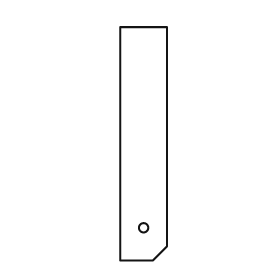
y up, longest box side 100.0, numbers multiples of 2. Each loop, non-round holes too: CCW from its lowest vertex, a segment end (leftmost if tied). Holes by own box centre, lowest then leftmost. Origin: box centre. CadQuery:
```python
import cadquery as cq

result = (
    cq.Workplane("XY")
    .moveTo(-10.0, -50.0)
    .lineTo(4.0, -50.0)
    .lineTo(10.0, -44.0)
    .lineTo(10.0, 50.0)
    .lineTo(-10.0, 50.0)
    .close()
    .moveTo(0.0, -36.0)
    .circle(2.0)
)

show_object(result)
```